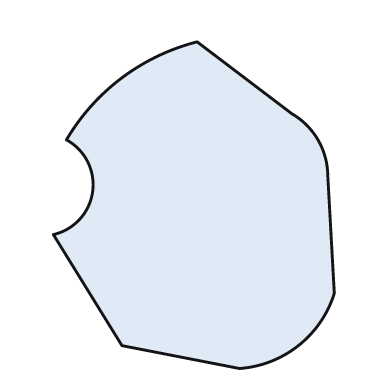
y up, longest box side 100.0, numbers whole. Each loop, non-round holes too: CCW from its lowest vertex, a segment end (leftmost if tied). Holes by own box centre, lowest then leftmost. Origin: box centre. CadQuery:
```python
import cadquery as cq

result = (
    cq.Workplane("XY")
    .moveTo(14.0, -50.0)
    .threePointArc((32.0, -43.0), (43.0, -27.0))
    .lineTo(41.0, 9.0)
    .threePointArc((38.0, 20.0), (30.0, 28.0))
    .lineTo(1.0, 50.0)
    .threePointArc((-22.0, 39.0), (-39.0, 20.0))
    .threePointArc((-31.0, 4.0), (-43.0, -9.0))
    .lineTo(-22.0, -43.0)
    .close()
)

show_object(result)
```